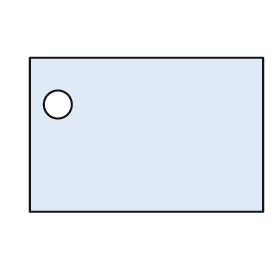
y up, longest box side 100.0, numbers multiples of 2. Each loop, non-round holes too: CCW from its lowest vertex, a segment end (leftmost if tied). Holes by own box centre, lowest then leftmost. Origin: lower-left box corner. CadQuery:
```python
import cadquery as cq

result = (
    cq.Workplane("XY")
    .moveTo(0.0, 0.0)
    .lineTo(100.0, 0.0)
    .lineTo(100.0, 66.0)
    .lineTo(0.0, 66.0)
    .close()
    .moveTo(12.0, 46.0)
    .circle(6.0)
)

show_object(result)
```